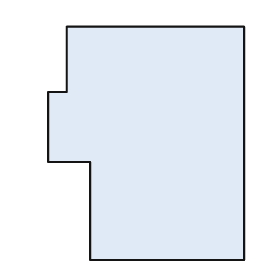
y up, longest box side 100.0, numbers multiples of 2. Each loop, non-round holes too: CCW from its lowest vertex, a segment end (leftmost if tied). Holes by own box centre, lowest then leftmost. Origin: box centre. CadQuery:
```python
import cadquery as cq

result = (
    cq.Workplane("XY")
    .moveTo(-24.0, -50.0)
    .lineTo(42.0, -50.0)
    .lineTo(42.0, 50.0)
    .lineTo(-34.0, 50.0)
    .lineTo(-34.0, 22.0)
    .lineTo(-42.0, 22.0)
    .lineTo(-42.0, -8.0)
    .lineTo(-24.0, -8.0)
    .close()
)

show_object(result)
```